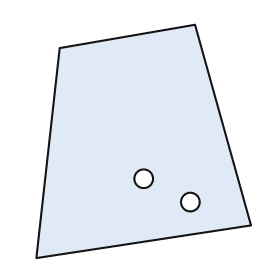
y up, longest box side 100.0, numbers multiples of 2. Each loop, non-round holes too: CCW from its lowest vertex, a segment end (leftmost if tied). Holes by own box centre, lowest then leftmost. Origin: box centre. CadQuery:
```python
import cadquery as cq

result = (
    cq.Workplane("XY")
    .moveTo(-46.0, -50.0)
    .lineTo(46.0, -36.0)
    .lineTo(22.0, 50.0)
    .lineTo(-36.0, 40.0)
    .close()
    .moveTo(20.0, -26.0)
    .circle(4.0)
    .moveTo(0.0, -16.0)
    .circle(4.0)
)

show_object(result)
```